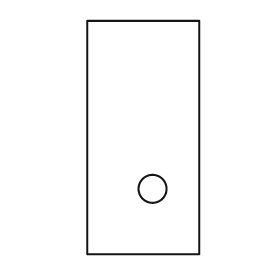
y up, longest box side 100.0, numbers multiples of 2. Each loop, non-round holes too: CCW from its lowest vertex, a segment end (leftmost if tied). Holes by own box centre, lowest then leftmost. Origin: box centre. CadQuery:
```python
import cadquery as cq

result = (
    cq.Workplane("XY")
    .moveTo(-24.0, -50.0)
    .lineTo(24.0, -50.0)
    .lineTo(24.0, 50.0)
    .lineTo(-24.0, 50.0)
    .close()
    .moveTo(4.0, -22.0)
    .circle(6.0)
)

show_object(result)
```